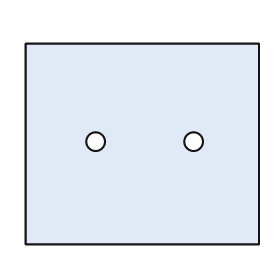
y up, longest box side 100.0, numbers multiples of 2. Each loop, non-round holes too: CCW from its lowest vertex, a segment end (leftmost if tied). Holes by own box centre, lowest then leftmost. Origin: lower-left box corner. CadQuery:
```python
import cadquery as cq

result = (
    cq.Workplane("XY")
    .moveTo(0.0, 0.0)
    .lineTo(100.0, 0.0)
    .lineTo(100.0, 86.0)
    .lineTo(0.0, 86.0)
    .close()
    .moveTo(30.0, 44.0)
    .circle(4.0)
    .moveTo(72.0, 44.0)
    .circle(4.0)
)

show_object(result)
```